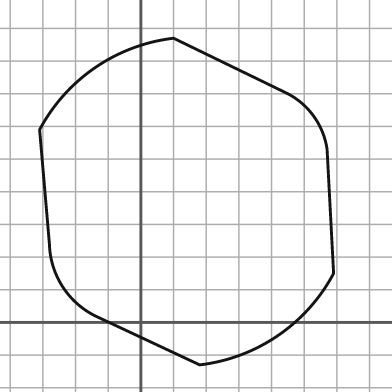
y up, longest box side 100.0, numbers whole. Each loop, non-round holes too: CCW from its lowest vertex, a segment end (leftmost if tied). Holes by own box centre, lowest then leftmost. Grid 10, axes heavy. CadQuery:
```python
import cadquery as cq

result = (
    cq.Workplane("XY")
    .moveTo(18.0, -13.0)
    .threePointArc((42.0, -4.0), (59.0, 15.0))
    .lineTo(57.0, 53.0)
    .threePointArc((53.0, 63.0), (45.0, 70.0))
    .lineTo(10.0, 87.0)
    .threePointArc((-14.0, 78.0), (-31.0, 59.0))
    .lineTo(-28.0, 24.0)
    .threePointArc((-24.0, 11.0), (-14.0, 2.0))
    .close()
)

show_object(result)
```